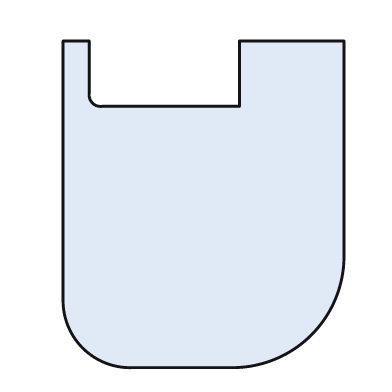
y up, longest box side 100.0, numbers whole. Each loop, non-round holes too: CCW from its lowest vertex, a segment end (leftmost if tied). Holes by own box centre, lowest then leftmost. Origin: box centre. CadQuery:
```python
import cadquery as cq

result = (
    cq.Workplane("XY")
    .moveTo(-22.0, -50.0)
    .lineTo(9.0, -50.0)
    .threePointArc((33.0, -40.0), (43.0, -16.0))
    .lineTo(43.0, 50.0)
    .lineTo(11.0, 50.0)
    .lineTo(11.0, 30.0)
    .lineTo(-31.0, 30.0)
    .threePointArc((-34.0, 31.0), (-35.0, 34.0))
    .lineTo(-35.0, 50.0)
    .lineTo(-43.0, 50.0)
    .lineTo(-43.0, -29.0)
    .threePointArc((-37.0, -44.0), (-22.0, -50.0))
    .close()
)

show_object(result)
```